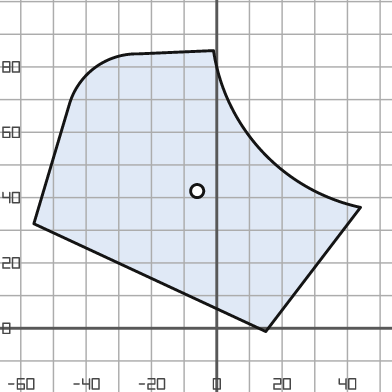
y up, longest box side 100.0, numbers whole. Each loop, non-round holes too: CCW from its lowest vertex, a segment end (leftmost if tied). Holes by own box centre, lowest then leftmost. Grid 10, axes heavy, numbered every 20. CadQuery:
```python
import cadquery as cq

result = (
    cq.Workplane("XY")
    .moveTo(15.0, -1.0)
    .lineTo(44.0, 37.0)
    .threePointArc((14.0, 54.0), (-1.0, 85.0))
    .lineTo(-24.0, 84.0)
    .threePointArc((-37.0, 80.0), (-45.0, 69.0))
    .lineTo(-56.0, 32.0)
    .close()
    .moveTo(-6.0, 42.0)
    .circle(2.0)
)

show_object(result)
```